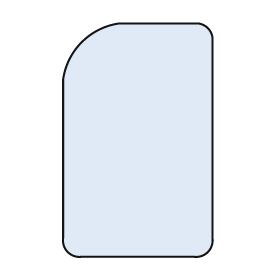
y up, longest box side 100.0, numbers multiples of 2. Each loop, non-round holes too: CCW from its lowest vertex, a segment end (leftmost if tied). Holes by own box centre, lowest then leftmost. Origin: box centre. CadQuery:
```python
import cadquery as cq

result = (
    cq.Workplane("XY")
    .moveTo(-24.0, -50.0)
    .lineTo(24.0, -50.0)
    .threePointArc((30.0, -48.0), (32.0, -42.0))
    .lineTo(32.0, 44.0)
    .threePointArc((30.0, 48.0), (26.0, 50.0))
    .lineTo(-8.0, 50.0)
    .threePointArc((-24.0, 42.0), (-32.0, 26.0))
    .lineTo(-32.0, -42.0)
    .threePointArc((-30.0, -48.0), (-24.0, -50.0))
    .close()
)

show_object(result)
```